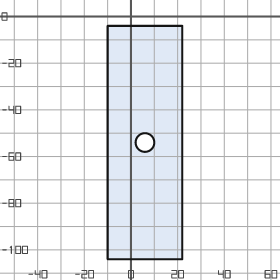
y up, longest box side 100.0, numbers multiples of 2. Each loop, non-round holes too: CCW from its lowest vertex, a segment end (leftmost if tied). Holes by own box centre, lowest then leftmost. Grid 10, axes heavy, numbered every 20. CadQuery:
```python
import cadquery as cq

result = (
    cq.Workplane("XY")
    .moveTo(-10.0, -104.0)
    .lineTo(22.0, -104.0)
    .lineTo(22.0, -4.0)
    .lineTo(-10.0, -4.0)
    .close()
    .moveTo(6.0, -54.0)
    .circle(4.0)
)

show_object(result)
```